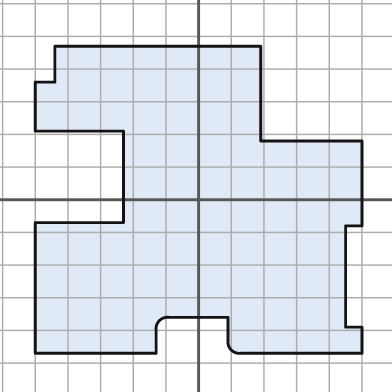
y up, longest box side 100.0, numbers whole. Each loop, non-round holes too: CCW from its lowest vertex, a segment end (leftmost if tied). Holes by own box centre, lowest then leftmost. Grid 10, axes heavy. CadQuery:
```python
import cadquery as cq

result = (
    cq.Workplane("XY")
    .moveTo(-50.0, -47.0)
    .lineTo(-13.0, -47.0)
    .lineTo(-13.0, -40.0)
    .threePointArc((-12.0, -37.0), (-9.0, -36.0))
    .lineTo(9.0, -36.0)
    .lineTo(9.0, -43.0)
    .threePointArc((10.0, -46.0), (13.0, -47.0))
    .lineTo(50.0, -47.0)
    .lineTo(50.0, -39.0)
    .lineTo(45.0, -39.0)
    .lineTo(45.0, -8.0)
    .lineTo(50.0, -8.0)
    .lineTo(50.0, 18.0)
    .lineTo(19.0, 18.0)
    .lineTo(19.0, 47.0)
    .lineTo(-44.0, 47.0)
    .lineTo(-44.0, 36.0)
    .lineTo(-50.0, 36.0)
    .lineTo(-50.0, 21.0)
    .lineTo(-23.0, 21.0)
    .lineTo(-23.0, -7.0)
    .lineTo(-50.0, -7.0)
    .close()
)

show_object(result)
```